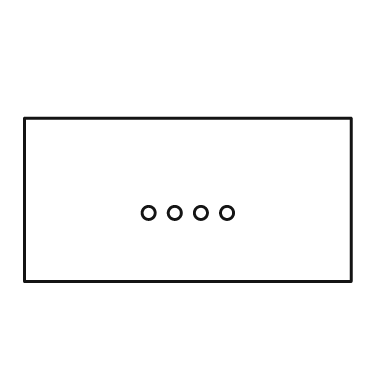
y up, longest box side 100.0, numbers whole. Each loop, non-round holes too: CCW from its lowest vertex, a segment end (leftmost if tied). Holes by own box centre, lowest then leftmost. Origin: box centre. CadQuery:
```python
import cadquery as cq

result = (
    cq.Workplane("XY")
    .moveTo(-50.0, -25.0)
    .lineTo(50.0, -25.0)
    .lineTo(50.0, 25.0)
    .lineTo(-50.0, 25.0)
    .close()
    .moveTo(-12.0, -4.0)
    .circle(2.0)
    .moveTo(-4.0, -4.0)
    .circle(2.0)
    .moveTo(4.0, -4.0)
    .circle(2.0)
    .moveTo(12.0, -4.0)
    .circle(2.0)
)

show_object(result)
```